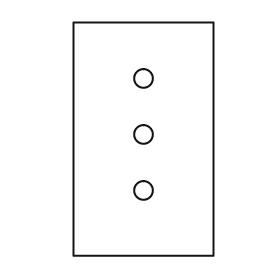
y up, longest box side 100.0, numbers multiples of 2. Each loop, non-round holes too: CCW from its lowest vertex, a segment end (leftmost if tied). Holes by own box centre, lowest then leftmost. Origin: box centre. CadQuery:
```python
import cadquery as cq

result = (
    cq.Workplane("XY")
    .moveTo(-30.0, -50.0)
    .lineTo(30.0, -50.0)
    .lineTo(30.0, 50.0)
    .lineTo(-30.0, 50.0)
    .close()
    .moveTo(0.0, -22.0)
    .circle(4.0)
    .moveTo(0.0, 2.0)
    .circle(4.0)
    .moveTo(0.0, 26.0)
    .circle(4.0)
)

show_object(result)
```